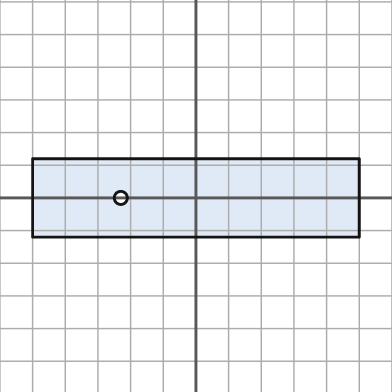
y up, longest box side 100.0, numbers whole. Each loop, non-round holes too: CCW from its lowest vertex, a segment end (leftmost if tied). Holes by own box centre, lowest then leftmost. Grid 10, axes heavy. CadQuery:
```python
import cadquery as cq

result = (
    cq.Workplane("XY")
    .moveTo(-50.0, -12.0)
    .lineTo(50.0, -12.0)
    .lineTo(50.0, 12.0)
    .lineTo(-50.0, 12.0)
    .close()
    .moveTo(-23.0, 0.0)
    .circle(2.0)
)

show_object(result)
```